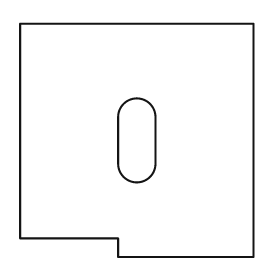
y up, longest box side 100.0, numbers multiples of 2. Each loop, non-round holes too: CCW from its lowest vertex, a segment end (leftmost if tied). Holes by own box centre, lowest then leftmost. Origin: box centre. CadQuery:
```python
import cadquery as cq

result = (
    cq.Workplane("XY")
    .moveTo(-8.0, -50.0)
    .lineTo(50.0, -50.0)
    .lineTo(50.0, 50.0)
    .lineTo(-50.0, 50.0)
    .lineTo(-50.0, -42.0)
    .lineTo(-8.0, -42.0)
    .close()
    .moveTo(-8.0, -10.0)
    .threePointArc((0.0, -18.0), (8.0, -10.0))
    .lineTo(8.0, 10.0)
    .threePointArc((0.0, 18.0), (-8.0, 10.0))
    .close()
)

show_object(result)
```